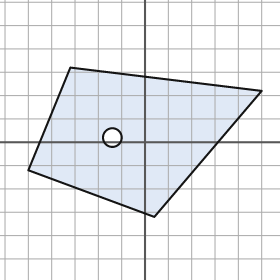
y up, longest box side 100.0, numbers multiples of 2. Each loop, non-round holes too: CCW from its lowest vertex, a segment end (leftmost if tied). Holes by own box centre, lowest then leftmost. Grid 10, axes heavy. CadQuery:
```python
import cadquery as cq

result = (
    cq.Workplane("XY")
    .moveTo(4.0, -32.0)
    .lineTo(50.0, 22.0)
    .lineTo(-32.0, 32.0)
    .lineTo(-50.0, -12.0)
    .close()
    .moveTo(-14.0, 2.0)
    .circle(4.0)
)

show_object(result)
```